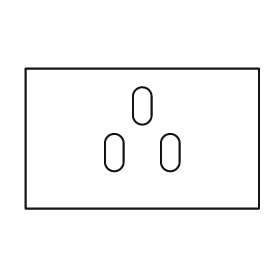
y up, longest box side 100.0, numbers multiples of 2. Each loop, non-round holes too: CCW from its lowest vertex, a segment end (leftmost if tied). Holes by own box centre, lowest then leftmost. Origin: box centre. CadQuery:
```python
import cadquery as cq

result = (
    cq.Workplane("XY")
    .moveTo(-50.0, -30.0)
    .lineTo(50.0, -30.0)
    .lineTo(50.0, 30.0)
    .lineTo(-50.0, 30.0)
    .close()
    .moveTo(-16.0, -10.0)
    .threePointArc((-12.0, -14.0), (-8.0, -10.0))
    .lineTo(-8.0, -2.0)
    .threePointArc((-12.0, 2.0), (-16.0, -2.0))
    .close()
    .moveTo(8.0, -10.0)
    .threePointArc((12.0, -14.0), (16.0, -10.0))
    .lineTo(16.0, -2.0)
    .threePointArc((12.0, 2.0), (8.0, -2.0))
    .close()
    .moveTo(-4.0, 10.0)
    .threePointArc((0.0, 6.0), (4.0, 10.0))
    .lineTo(4.0, 18.0)
    .threePointArc((0.0, 22.0), (-4.0, 18.0))
    .close()
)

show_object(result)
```